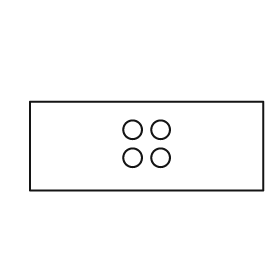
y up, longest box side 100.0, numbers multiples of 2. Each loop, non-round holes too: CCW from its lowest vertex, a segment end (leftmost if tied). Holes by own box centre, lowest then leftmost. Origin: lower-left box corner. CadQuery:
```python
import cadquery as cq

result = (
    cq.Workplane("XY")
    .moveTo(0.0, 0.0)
    .lineTo(100.0, 0.0)
    .lineTo(100.0, 38.0)
    .lineTo(0.0, 38.0)
    .close()
    .moveTo(44.0, 14.0)
    .circle(4.0)
    .moveTo(56.0, 14.0)
    .circle(4.0)
    .moveTo(44.0, 26.0)
    .circle(4.0)
    .moveTo(56.0, 26.0)
    .circle(4.0)
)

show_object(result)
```